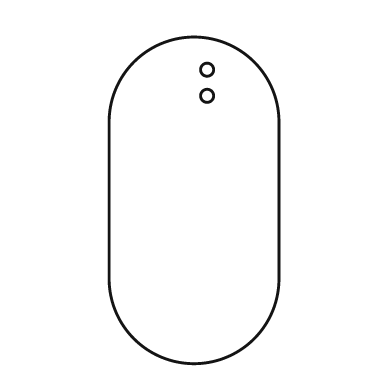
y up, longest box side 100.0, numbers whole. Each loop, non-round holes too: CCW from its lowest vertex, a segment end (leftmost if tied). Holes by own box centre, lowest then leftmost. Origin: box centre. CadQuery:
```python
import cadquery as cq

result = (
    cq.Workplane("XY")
    .moveTo(-26.0, -24.0)
    .threePointArc((0.0, -50.0), (26.0, -24.0))
    .lineTo(26.0, 24.0)
    .threePointArc((0.0, 50.0), (-26.0, 24.0))
    .close()
    .moveTo(4.0, 32.0)
    .circle(2.0)
    .moveTo(4.0, 40.0)
    .circle(2.0)
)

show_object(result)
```